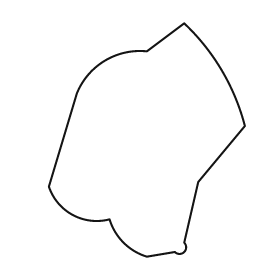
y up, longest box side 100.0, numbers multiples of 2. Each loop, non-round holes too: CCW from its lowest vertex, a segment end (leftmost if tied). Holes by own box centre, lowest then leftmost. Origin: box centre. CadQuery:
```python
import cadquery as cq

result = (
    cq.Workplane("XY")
    .moveTo(0.0, -50.0)
    .lineTo(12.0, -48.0)
    .threePointArc((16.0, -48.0), (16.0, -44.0))
    .lineTo(22.0, -18.0)
    .lineTo(42.0, 6.0)
    .threePointArc((32.0, 30.0), (16.0, 50.0))
    .lineTo(0.0, 38.0)
    .threePointArc((-18.0, 34.0), (-30.0, 20.0))
    .lineTo(-42.0, -20.0)
    .threePointArc((-32.0, -32.0), (-16.0, -34.0))
    .threePointArc((-10.0, -44.0), (0.0, -50.0))
    .close()
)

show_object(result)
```